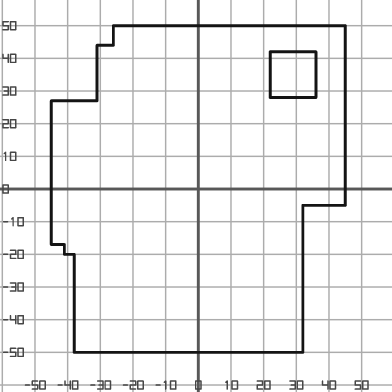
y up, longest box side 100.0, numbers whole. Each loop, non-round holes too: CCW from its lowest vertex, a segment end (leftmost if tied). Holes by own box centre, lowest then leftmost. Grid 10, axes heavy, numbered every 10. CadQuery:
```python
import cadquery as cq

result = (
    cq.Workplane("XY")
    .moveTo(-38.0, -50.0)
    .lineTo(32.0, -50.0)
    .lineTo(32.0, -5.0)
    .lineTo(45.0, -5.0)
    .lineTo(45.0, 50.0)
    .lineTo(-26.0, 50.0)
    .lineTo(-26.0, 44.0)
    .lineTo(-31.0, 44.0)
    .lineTo(-31.0, 27.0)
    .lineTo(-45.0, 27.0)
    .lineTo(-45.0, -17.0)
    .lineTo(-41.0, -17.0)
    .lineTo(-41.0, -20.0)
    .lineTo(-38.0, -20.0)
    .close()
    .moveTo(22.0, 28.0)
    .lineTo(36.0, 28.0)
    .lineTo(36.0, 42.0)
    .lineTo(22.0, 42.0)
    .close()
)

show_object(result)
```